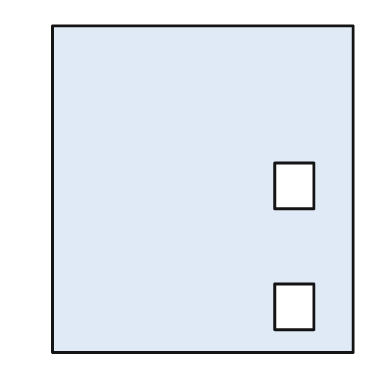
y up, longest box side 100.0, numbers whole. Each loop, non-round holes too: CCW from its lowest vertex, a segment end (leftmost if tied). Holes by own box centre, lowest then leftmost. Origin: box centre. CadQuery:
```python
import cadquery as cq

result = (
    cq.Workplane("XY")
    .moveTo(-46.0, -50.0)
    .lineTo(46.0, -50.0)
    .lineTo(46.0, 50.0)
    .lineTo(-46.0, 50.0)
    .close()
    .moveTo(22.0, -43.0)
    .lineTo(34.0, -43.0)
    .lineTo(34.0, -29.0)
    .lineTo(22.0, -29.0)
    .close()
    .moveTo(22.0, -6.0)
    .lineTo(34.0, -6.0)
    .lineTo(34.0, 8.0)
    .lineTo(22.0, 8.0)
    .close()
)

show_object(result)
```